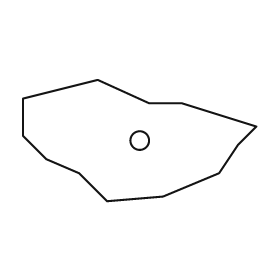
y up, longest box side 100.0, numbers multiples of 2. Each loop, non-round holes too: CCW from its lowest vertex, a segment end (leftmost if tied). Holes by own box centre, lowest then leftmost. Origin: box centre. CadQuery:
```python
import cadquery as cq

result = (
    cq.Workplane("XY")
    .moveTo(-14.0, -26.0)
    .lineTo(10.0, -24.0)
    .lineTo(34.0, -14.0)
    .lineTo(42.0, -2.0)
    .lineTo(50.0, 6.0)
    .lineTo(18.0, 16.0)
    .lineTo(4.0, 16.0)
    .lineTo(-18.0, 26.0)
    .lineTo(-50.0, 18.0)
    .lineTo(-50.0, 2.0)
    .lineTo(-40.0, -8.0)
    .lineTo(-26.0, -14.0)
    .close()
    .moveTo(0.0, 0.0)
    .circle(4.0)
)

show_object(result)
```